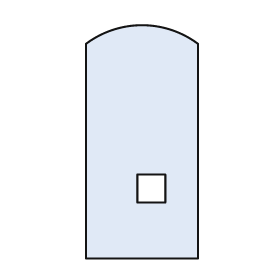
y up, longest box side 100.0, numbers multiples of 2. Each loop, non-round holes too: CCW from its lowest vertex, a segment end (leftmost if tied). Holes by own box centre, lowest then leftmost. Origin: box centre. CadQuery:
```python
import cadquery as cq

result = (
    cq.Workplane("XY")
    .moveTo(-24.0, -50.0)
    .lineTo(24.0, -50.0)
    .lineTo(24.0, 42.0)
    .threePointArc((0.0, 50.0), (-24.0, 42.0))
    .close()
    .moveTo(-2.0, -26.0)
    .lineTo(10.0, -26.0)
    .lineTo(10.0, -14.0)
    .lineTo(-2.0, -14.0)
    .close()
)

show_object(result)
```